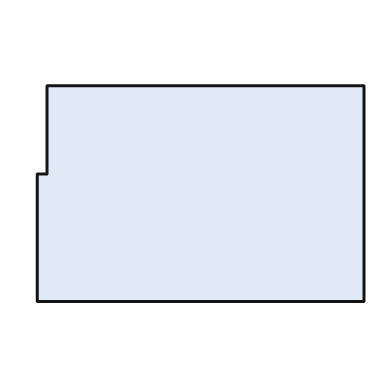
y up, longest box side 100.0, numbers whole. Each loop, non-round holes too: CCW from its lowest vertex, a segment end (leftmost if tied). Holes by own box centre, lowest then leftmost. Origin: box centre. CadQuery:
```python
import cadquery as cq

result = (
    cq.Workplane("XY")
    .moveTo(-50.0, -33.0)
    .lineTo(50.0, -33.0)
    .lineTo(50.0, 33.0)
    .lineTo(-47.0, 33.0)
    .lineTo(-47.0, 6.0)
    .lineTo(-50.0, 6.0)
    .close()
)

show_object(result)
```